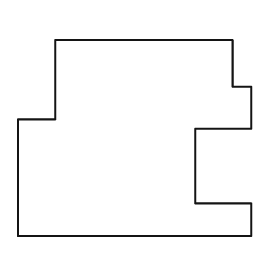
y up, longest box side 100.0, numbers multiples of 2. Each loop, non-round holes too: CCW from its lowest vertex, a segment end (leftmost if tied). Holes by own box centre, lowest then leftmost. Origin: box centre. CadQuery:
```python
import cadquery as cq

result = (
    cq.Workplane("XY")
    .moveTo(-50.0, -42.0)
    .lineTo(50.0, -42.0)
    .lineTo(50.0, -28.0)
    .lineTo(26.0, -28.0)
    .lineTo(26.0, 4.0)
    .lineTo(50.0, 4.0)
    .lineTo(50.0, 22.0)
    .lineTo(42.0, 22.0)
    .lineTo(42.0, 42.0)
    .lineTo(-34.0, 42.0)
    .lineTo(-34.0, 8.0)
    .lineTo(-50.0, 8.0)
    .close()
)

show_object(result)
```